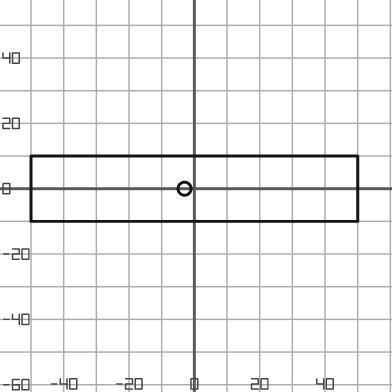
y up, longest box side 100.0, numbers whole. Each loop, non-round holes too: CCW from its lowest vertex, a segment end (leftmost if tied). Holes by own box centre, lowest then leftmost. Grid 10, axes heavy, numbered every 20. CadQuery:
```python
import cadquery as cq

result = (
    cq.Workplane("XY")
    .moveTo(-50.0, -10.0)
    .lineTo(50.0, -10.0)
    .lineTo(50.0, 10.0)
    .lineTo(-50.0, 10.0)
    .close()
    .moveTo(-3.0, 0.0)
    .circle(2.0)
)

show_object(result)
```